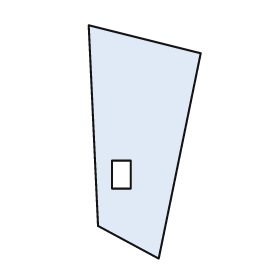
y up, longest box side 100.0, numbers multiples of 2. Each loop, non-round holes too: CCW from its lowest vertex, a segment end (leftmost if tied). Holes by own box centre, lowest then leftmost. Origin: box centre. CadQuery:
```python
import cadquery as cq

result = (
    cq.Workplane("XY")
    .moveTo(6.0, -50.0)
    .lineTo(24.0, 38.0)
    .lineTo(-24.0, 50.0)
    .lineTo(-20.0, -36.0)
    .close()
    .moveTo(-14.0, -20.0)
    .lineTo(-6.0, -20.0)
    .lineTo(-6.0, -8.0)
    .lineTo(-14.0, -8.0)
    .close()
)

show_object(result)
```